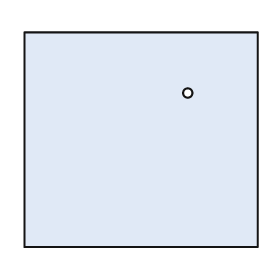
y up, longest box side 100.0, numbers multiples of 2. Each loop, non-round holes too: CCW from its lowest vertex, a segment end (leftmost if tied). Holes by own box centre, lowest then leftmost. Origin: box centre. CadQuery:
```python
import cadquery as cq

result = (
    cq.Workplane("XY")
    .moveTo(-50.0, -46.0)
    .lineTo(50.0, -46.0)
    .lineTo(50.0, 46.0)
    .lineTo(-50.0, 46.0)
    .close()
    .moveTo(20.0, 20.0)
    .circle(2.0)
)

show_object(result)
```